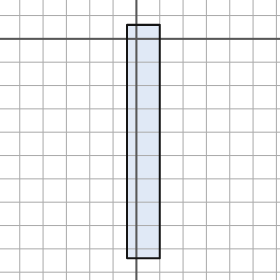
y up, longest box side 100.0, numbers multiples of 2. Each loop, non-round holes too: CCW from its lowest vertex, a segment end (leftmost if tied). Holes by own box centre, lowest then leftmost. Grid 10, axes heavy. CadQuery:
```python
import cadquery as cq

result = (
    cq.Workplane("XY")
    .moveTo(-4.0, -94.0)
    .lineTo(10.0, -94.0)
    .lineTo(10.0, 6.0)
    .lineTo(-4.0, 6.0)
    .close()
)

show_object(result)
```